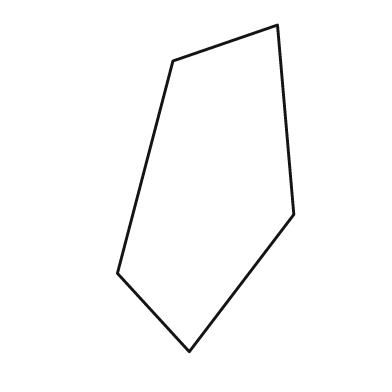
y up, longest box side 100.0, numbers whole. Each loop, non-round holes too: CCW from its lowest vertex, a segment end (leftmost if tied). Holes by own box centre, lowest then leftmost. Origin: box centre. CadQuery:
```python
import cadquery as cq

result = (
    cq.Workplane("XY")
    .moveTo(-5.0, -50.0)
    .lineTo(27.0, -8.0)
    .lineTo(22.0, 50.0)
    .lineTo(-10.0, 39.0)
    .lineTo(-27.0, -26.0)
    .close()
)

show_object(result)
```